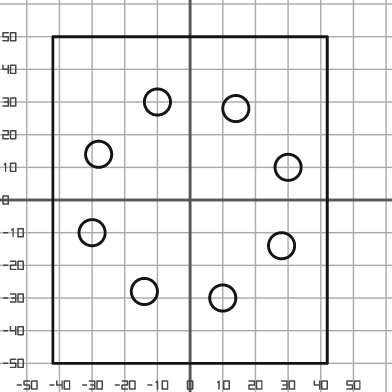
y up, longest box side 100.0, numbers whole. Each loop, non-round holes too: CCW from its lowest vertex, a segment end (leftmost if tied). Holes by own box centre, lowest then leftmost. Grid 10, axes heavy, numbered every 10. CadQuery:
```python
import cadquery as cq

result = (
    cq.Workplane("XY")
    .moveTo(-42.0, -50.0)
    .lineTo(42.0, -50.0)
    .lineTo(42.0, 50.0)
    .lineTo(-42.0, 50.0)
    .close()
    .moveTo(10.0, -30.0)
    .circle(4.0)
    .moveTo(-14.0, -28.0)
    .circle(4.0)
    .moveTo(28.0, -14.0)
    .circle(4.0)
    .moveTo(-30.0, -10.0)
    .circle(4.0)
    .moveTo(30.0, 10.0)
    .circle(4.0)
    .moveTo(-28.0, 14.0)
    .circle(4.0)
    .moveTo(14.0, 28.0)
    .circle(4.0)
    .moveTo(-10.0, 30.0)
    .circle(4.0)
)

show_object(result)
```